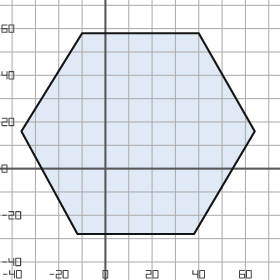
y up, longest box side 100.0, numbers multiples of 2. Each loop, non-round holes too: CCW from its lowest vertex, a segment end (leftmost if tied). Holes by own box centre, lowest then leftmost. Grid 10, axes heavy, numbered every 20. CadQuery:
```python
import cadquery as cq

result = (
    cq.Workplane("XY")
    .moveTo(-12.0, -28.0)
    .lineTo(38.0, -28.0)
    .lineTo(64.0, 16.0)
    .lineTo(40.0, 58.0)
    .lineTo(-10.0, 58.0)
    .lineTo(-36.0, 16.0)
    .close()
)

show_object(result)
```